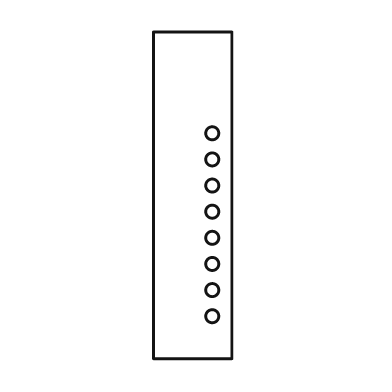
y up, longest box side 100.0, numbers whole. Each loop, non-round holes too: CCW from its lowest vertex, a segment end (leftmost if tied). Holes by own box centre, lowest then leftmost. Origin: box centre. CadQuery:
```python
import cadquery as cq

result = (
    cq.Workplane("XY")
    .moveTo(-12.0, -50.0)
    .lineTo(12.0, -50.0)
    .lineTo(12.0, 50.0)
    .lineTo(-12.0, 50.0)
    .close()
    .moveTo(6.0, -37.0)
    .circle(2.0)
    .moveTo(6.0, -29.0)
    .circle(2.0)
    .moveTo(6.0, -21.0)
    .circle(2.0)
    .moveTo(6.0, -13.0)
    .circle(2.0)
    .moveTo(6.0, -5.0)
    .circle(2.0)
    .moveTo(6.0, 3.0)
    .circle(2.0)
    .moveTo(6.0, 11.0)
    .circle(2.0)
    .moveTo(6.0, 19.0)
    .circle(2.0)
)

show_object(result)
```